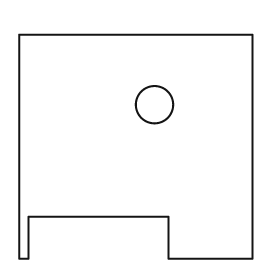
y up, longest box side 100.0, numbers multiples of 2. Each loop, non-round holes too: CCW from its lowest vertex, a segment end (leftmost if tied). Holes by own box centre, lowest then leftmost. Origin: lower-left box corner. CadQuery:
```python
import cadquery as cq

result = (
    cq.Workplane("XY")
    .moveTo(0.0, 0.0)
    .lineTo(4.0, 0.0)
    .lineTo(4.0, 18.0)
    .lineTo(64.0, 18.0)
    .lineTo(64.0, 0.0)
    .lineTo(100.0, 0.0)
    .lineTo(100.0, 96.0)
    .lineTo(0.0, 96.0)
    .close()
    .moveTo(58.0, 66.0)
    .circle(8.0)
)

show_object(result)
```